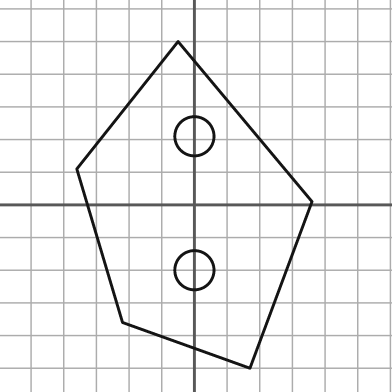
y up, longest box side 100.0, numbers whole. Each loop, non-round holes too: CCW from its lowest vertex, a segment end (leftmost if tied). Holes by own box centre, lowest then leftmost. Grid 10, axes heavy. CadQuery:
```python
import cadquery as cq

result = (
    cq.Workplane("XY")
    .moveTo(17.0, -50.0)
    .lineTo(36.0, 1.0)
    .lineTo(-5.0, 50.0)
    .lineTo(-36.0, 11.0)
    .lineTo(-22.0, -36.0)
    .close()
    .moveTo(0.0, -20.0)
    .circle(6.0)
    .moveTo(0.0, 21.0)
    .circle(6.0)
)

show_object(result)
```